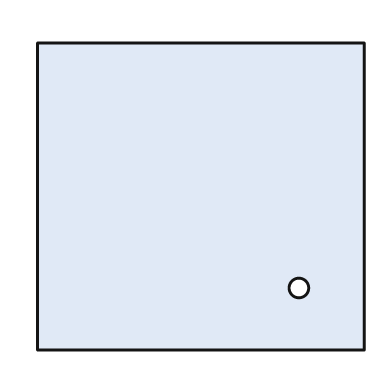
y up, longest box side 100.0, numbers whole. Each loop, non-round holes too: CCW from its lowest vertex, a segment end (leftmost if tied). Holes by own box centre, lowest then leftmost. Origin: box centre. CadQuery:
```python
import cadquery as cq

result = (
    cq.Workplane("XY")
    .moveTo(-50.0, -47.0)
    .lineTo(50.0, -47.0)
    .lineTo(50.0, 47.0)
    .lineTo(-50.0, 47.0)
    .close()
    .moveTo(30.0, -28.0)
    .circle(3.0)
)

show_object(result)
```